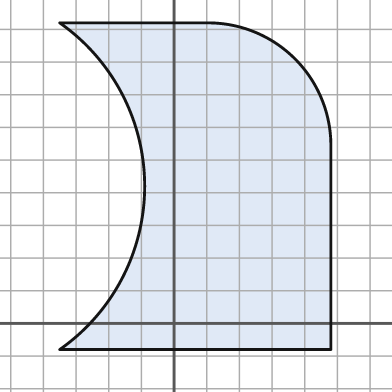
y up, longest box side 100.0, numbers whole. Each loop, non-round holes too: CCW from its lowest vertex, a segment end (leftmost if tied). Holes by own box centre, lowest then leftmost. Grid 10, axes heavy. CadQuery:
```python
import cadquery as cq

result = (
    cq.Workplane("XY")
    .moveTo(-35.0, -8.0)
    .lineTo(48.0, -8.0)
    .lineTo(48.0, 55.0)
    .threePointArc((37.0, 81.0), (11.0, 92.0))
    .lineTo(-35.0, 92.0)
    .threePointArc((-9.0, 42.0), (-35.0, -8.0))
    .close()
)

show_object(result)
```